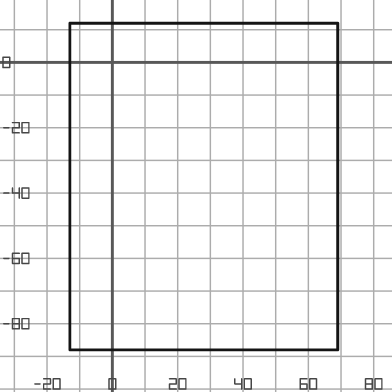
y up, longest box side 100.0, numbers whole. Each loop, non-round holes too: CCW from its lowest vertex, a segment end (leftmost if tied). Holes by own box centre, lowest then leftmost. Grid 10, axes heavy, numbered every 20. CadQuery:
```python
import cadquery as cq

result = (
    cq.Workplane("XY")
    .moveTo(-13.0, -88.0)
    .lineTo(69.0, -88.0)
    .lineTo(69.0, 12.0)
    .lineTo(-13.0, 12.0)
    .close()
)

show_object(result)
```